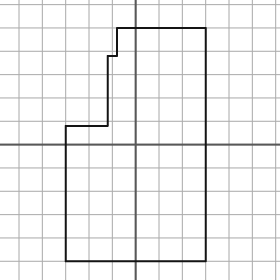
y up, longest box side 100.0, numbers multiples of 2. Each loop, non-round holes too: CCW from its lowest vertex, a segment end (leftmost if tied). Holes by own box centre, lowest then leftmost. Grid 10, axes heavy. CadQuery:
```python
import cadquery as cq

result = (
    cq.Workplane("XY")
    .moveTo(-30.0, -50.0)
    .lineTo(30.0, -50.0)
    .lineTo(30.0, 50.0)
    .lineTo(-8.0, 50.0)
    .lineTo(-8.0, 38.0)
    .lineTo(-12.0, 38.0)
    .lineTo(-12.0, 8.0)
    .lineTo(-30.0, 8.0)
    .close()
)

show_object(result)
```